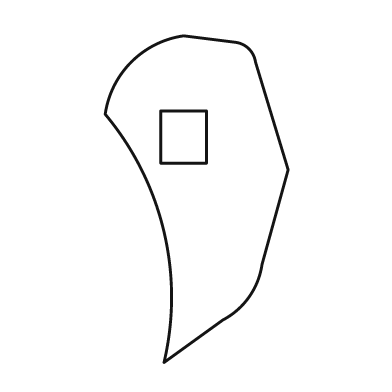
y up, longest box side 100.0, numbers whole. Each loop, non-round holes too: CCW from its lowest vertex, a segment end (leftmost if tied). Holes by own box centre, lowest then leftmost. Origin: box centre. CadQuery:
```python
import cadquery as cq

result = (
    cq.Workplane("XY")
    .moveTo(-10.0, -50.0)
    .lineTo(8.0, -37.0)
    .threePointArc((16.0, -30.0), (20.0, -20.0))
    .lineTo(28.0, 9.0)
    .lineTo(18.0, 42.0)
    .threePointArc((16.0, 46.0), (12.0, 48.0))
    .lineTo(-4.0, 50.0)
    .threePointArc((-20.0, 42.0), (-28.0, 26.0))
    .threePointArc((-10.0, -10.0), (-10.0, -50.0))
    .close()
    .moveTo(-11.0, 11.0)
    .lineTo(3.0, 11.0)
    .lineTo(3.0, 27.0)
    .lineTo(-11.0, 27.0)
    .close()
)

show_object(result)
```